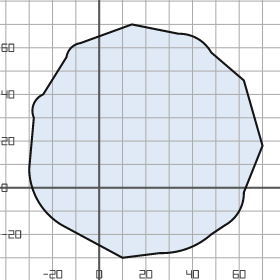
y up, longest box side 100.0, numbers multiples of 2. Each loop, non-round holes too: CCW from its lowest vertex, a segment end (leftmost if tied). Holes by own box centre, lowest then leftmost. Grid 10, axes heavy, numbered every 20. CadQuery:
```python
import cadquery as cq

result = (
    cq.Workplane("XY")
    .moveTo(10.0, -30.0)
    .lineTo(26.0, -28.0)
    .threePointArc((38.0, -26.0), (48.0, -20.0))
    .lineTo(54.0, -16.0)
    .threePointArc((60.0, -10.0), (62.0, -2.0))
    .lineTo(70.0, 18.0)
    .lineTo(62.0, 46.0)
    .lineTo(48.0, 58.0)
    .threePointArc((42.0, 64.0), (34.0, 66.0))
    .lineTo(14.0, 70.0)
    .lineTo(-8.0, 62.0)
    .threePointArc((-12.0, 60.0), (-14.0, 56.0))
    .lineTo(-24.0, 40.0)
    .threePointArc((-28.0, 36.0), (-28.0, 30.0))
    .lineTo(-30.0, 8.0)
    .threePointArc((-26.0, -6.0), (-16.0, -16.0))
    .close()
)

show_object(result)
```